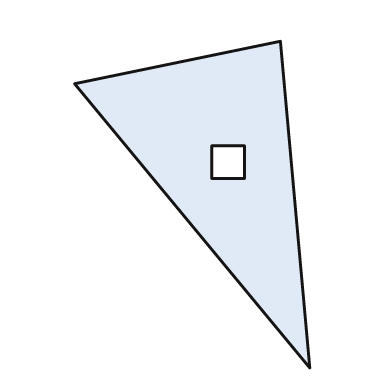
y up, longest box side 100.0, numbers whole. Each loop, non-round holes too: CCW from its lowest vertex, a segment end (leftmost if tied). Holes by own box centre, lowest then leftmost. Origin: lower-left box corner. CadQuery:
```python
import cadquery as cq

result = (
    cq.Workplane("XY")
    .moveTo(72.0, 0.0)
    .lineTo(63.0, 100.0)
    .lineTo(0.0, 87.0)
    .close()
    .moveTo(42.0, 58.0)
    .lineTo(52.0, 58.0)
    .lineTo(52.0, 68.0)
    .lineTo(42.0, 68.0)
    .close()
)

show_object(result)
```